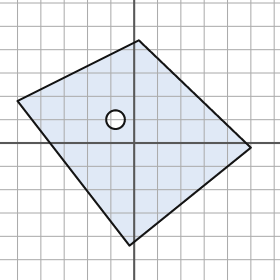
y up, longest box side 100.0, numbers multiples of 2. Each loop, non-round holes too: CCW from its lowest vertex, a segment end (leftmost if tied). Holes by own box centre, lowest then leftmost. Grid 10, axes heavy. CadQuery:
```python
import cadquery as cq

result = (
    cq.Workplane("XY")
    .moveTo(-2.0, -44.0)
    .lineTo(50.0, -2.0)
    .lineTo(2.0, 44.0)
    .lineTo(-50.0, 18.0)
    .close()
    .moveTo(-8.0, 10.0)
    .circle(4.0)
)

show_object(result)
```